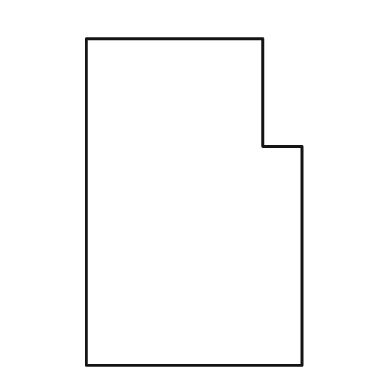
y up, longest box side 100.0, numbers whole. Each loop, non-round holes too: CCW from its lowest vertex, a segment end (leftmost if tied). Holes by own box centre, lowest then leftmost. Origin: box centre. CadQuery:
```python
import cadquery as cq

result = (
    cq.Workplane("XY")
    .moveTo(-33.0, -50.0)
    .lineTo(33.0, -50.0)
    .lineTo(33.0, 17.0)
    .lineTo(21.0, 17.0)
    .lineTo(21.0, 50.0)
    .lineTo(-33.0, 50.0)
    .close()
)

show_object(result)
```